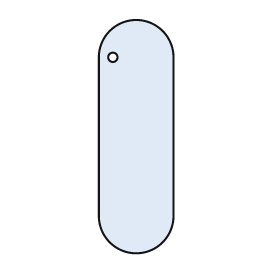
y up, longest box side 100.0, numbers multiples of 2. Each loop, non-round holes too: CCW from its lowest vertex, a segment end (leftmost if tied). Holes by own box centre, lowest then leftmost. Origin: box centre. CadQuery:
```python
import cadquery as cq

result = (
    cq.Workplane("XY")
    .moveTo(-16.0, -34.0)
    .threePointArc((0.0, -50.0), (16.0, -34.0))
    .lineTo(16.0, 34.0)
    .threePointArc((0.0, 50.0), (-16.0, 34.0))
    .close()
    .moveTo(-10.0, 34.0)
    .circle(2.0)
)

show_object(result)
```